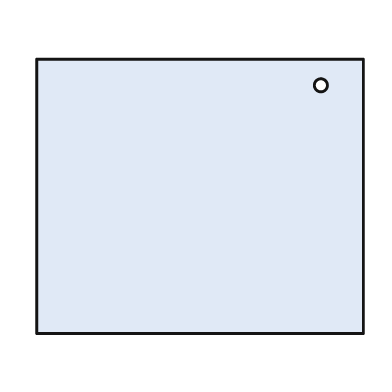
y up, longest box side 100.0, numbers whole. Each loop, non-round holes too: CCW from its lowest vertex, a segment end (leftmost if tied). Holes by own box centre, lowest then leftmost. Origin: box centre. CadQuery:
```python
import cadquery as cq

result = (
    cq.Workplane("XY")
    .moveTo(-50.0, -42.0)
    .lineTo(50.0, -42.0)
    .lineTo(50.0, 42.0)
    .lineTo(-50.0, 42.0)
    .close()
    .moveTo(37.0, 34.0)
    .circle(2.0)
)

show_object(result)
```